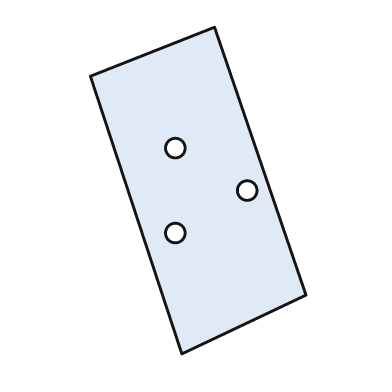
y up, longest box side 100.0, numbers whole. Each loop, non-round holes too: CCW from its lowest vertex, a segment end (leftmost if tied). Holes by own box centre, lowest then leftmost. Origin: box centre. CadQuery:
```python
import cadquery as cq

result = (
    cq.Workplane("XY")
    .moveTo(-5.0, -50.0)
    .lineTo(33.0, -32.0)
    .lineTo(5.0, 50.0)
    .lineTo(-33.0, 35.0)
    .close()
    .moveTo(-7.0, -13.0)
    .circle(3.0)
    .moveTo(15.0, 0.0)
    .circle(3.0)
    .moveTo(-7.0, 13.0)
    .circle(3.0)
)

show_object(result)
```